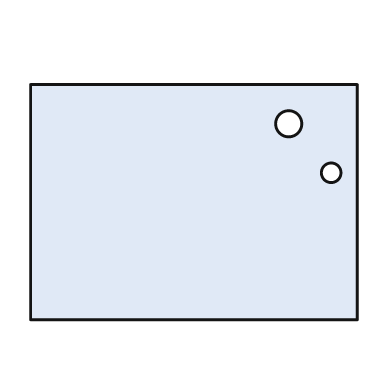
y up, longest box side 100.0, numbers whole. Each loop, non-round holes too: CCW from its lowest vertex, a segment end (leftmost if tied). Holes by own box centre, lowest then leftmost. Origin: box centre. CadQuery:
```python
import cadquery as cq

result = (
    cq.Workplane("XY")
    .moveTo(-50.0, -36.0)
    .lineTo(50.0, -36.0)
    .lineTo(50.0, 36.0)
    .lineTo(-50.0, 36.0)
    .close()
    .moveTo(42.0, 9.0)
    .circle(3.0)
    .moveTo(29.0, 24.0)
    .circle(4.0)
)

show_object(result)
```